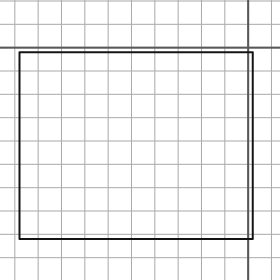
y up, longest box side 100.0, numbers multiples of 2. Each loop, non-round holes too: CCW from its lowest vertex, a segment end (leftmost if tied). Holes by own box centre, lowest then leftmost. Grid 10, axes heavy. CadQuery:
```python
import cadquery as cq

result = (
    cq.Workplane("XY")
    .moveTo(-98.0, -82.0)
    .lineTo(2.0, -82.0)
    .lineTo(2.0, -2.0)
    .lineTo(-98.0, -2.0)
    .close()
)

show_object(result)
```